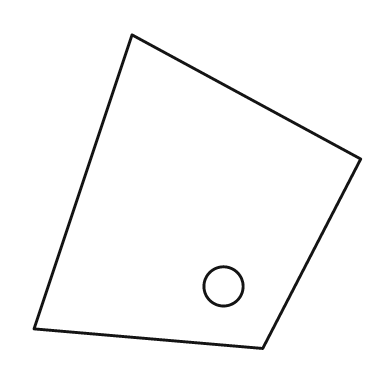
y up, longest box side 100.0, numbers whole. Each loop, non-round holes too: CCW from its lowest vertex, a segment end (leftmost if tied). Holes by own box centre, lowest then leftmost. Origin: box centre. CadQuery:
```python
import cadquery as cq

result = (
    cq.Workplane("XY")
    .moveTo(20.0, -48.0)
    .lineTo(50.0, 10.0)
    .lineTo(-20.0, 48.0)
    .lineTo(-50.0, -42.0)
    .close()
    .moveTo(8.0, -29.0)
    .circle(6.0)
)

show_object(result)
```